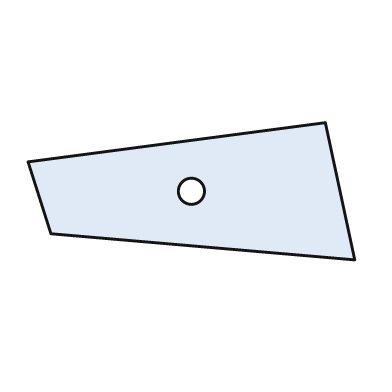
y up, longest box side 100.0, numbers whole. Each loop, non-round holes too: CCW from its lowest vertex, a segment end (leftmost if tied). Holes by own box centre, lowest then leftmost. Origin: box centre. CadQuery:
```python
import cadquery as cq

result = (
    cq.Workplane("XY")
    .moveTo(50.0, -21.0)
    .lineTo(41.0, 21.0)
    .lineTo(-50.0, 9.0)
    .lineTo(-43.0, -13.0)
    .close()
    .moveTo(0.0, 0.0)
    .circle(4.0)
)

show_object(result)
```